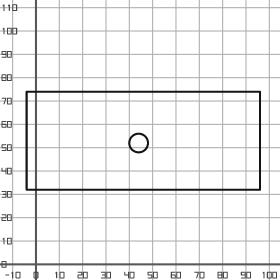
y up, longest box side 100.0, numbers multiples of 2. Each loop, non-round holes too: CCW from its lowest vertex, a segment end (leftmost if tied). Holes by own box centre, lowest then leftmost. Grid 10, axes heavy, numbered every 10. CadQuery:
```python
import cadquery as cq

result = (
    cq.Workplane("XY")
    .moveTo(-4.0, 32.0)
    .lineTo(96.0, 32.0)
    .lineTo(96.0, 74.0)
    .lineTo(-4.0, 74.0)
    .close()
    .moveTo(44.0, 52.0)
    .circle(4.0)
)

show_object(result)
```